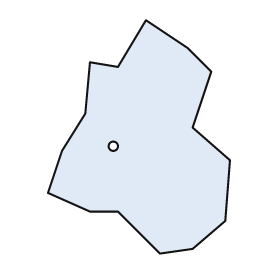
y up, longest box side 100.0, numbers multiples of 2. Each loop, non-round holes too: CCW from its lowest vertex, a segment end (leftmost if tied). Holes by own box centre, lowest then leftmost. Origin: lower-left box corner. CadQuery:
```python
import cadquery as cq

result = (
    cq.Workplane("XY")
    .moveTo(48.0, 0.0)
    .lineTo(62.0, 2.0)
    .lineTo(76.0, 14.0)
    .lineTo(78.0, 40.0)
    .lineTo(62.0, 54.0)
    .lineTo(70.0, 78.0)
    .lineTo(60.0, 88.0)
    .lineTo(42.0, 100.0)
    .lineTo(30.0, 80.0)
    .lineTo(18.0, 82.0)
    .lineTo(16.0, 60.0)
    .lineTo(6.0, 44.0)
    .lineTo(0.0, 26.0)
    .lineTo(18.0, 18.0)
    .lineTo(30.0, 18.0)
    .close()
    .moveTo(28.0, 46.0)
    .circle(2.0)
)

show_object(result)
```